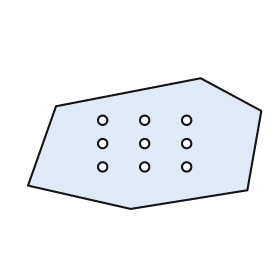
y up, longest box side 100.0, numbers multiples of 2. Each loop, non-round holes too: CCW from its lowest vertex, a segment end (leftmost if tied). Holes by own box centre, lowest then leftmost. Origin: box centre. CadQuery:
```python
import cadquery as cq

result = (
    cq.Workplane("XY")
    .moveTo(-6.0, -28.0)
    .lineTo(44.0, -20.0)
    .lineTo(50.0, 14.0)
    .lineTo(24.0, 28.0)
    .lineTo(-38.0, 16.0)
    .lineTo(-50.0, -18.0)
    .close()
    .moveTo(-18.0, -10.0)
    .circle(2.0)
    .moveTo(0.0, -10.0)
    .circle(2.0)
    .moveTo(18.0, -10.0)
    .circle(2.0)
    .moveTo(-18.0, 0.0)
    .circle(2.0)
    .moveTo(0.0, 0.0)
    .circle(2.0)
    .moveTo(18.0, 0.0)
    .circle(2.0)
    .moveTo(-18.0, 10.0)
    .circle(2.0)
    .moveTo(0.0, 10.0)
    .circle(2.0)
    .moveTo(18.0, 10.0)
    .circle(2.0)
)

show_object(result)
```